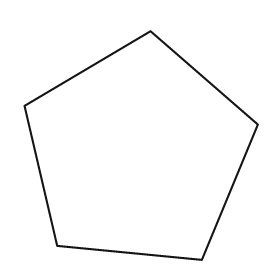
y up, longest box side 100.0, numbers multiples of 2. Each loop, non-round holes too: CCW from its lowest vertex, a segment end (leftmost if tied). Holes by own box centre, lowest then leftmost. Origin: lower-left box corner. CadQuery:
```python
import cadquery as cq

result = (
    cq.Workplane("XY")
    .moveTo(76.0, 0.0)
    .lineTo(100.0, 58.0)
    .lineTo(54.0, 98.0)
    .lineTo(0.0, 66.0)
    .lineTo(14.0, 6.0)
    .close()
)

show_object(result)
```